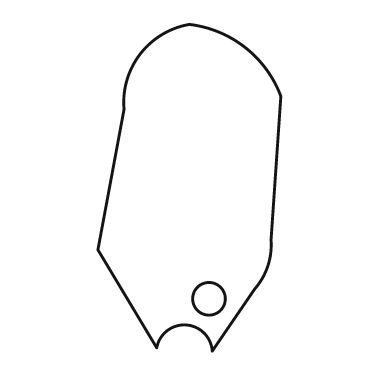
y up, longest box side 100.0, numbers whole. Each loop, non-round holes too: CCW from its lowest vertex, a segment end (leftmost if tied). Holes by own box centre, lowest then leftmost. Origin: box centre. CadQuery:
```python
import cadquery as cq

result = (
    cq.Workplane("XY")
    .moveTo(7.0, -50.0)
    .lineTo(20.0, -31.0)
    .threePointArc((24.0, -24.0), (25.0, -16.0))
    .lineTo(28.0, 28.0)
    .threePointArc((17.0, 43.0), (0.0, 50.0))
    .threePointArc((-15.0, 41.0), (-20.0, 24.0))
    .lineTo(-28.0, -19.0)
    .lineTo(-10.0, -49.0)
    .threePointArc((-1.0, -42.0), (7.0, -50.0))
    .close()
    .moveTo(6.0, -34.0)
    .circle(5.0)
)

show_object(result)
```